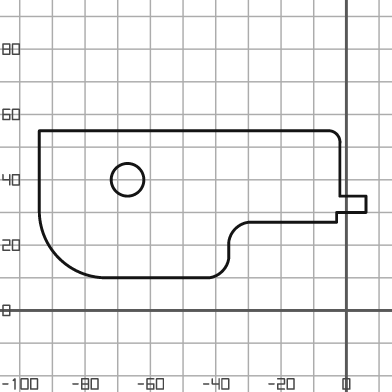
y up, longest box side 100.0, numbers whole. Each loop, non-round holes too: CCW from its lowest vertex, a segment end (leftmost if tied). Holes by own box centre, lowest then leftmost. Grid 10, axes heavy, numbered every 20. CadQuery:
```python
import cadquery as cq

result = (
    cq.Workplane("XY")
    .moveTo(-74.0, 10.0)
    .lineTo(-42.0, 10.0)
    .threePointArc((-38.0, 12.0), (-36.0, 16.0))
    .lineTo(-36.0, 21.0)
    .threePointArc((-34.0, 25.0), (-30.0, 27.0))
    .lineTo(-3.0, 27.0)
    .lineTo(-3.0, 30.0)
    .lineTo(6.0, 30.0)
    .lineTo(6.0, 35.0)
    .lineTo(-2.0, 35.0)
    .lineTo(-2.0, 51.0)
    .threePointArc((-3.0, 54.0), (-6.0, 55.0))
    .lineTo(-94.0, 55.0)
    .lineTo(-94.0, 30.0)
    .threePointArc((-88.0, 16.0), (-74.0, 10.0))
    .close()
    .moveTo(-67.0, 40.0)
    .circle(5.0)
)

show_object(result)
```